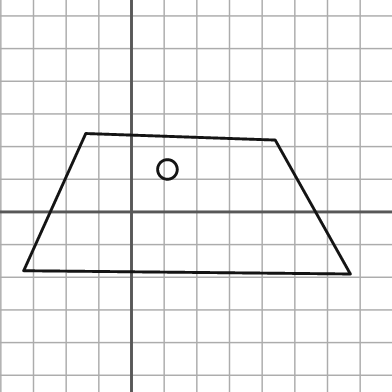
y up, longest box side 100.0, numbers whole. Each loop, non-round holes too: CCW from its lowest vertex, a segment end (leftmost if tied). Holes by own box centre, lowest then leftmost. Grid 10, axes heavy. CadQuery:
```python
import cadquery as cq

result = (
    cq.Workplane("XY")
    .moveTo(67.0, -19.0)
    .lineTo(44.0, 22.0)
    .lineTo(-14.0, 24.0)
    .lineTo(-33.0, -18.0)
    .close()
    .moveTo(11.0, 13.0)
    .circle(3.0)
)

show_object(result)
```